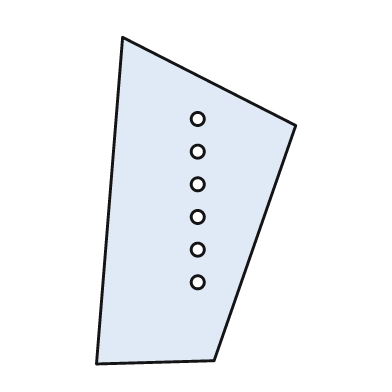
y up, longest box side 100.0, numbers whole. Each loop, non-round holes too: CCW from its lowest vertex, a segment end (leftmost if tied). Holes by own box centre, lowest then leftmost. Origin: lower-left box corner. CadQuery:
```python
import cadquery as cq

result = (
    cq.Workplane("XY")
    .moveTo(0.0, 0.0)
    .lineTo(36.0, 1.0)
    .lineTo(61.0, 73.0)
    .lineTo(8.0, 100.0)
    .close()
    .moveTo(31.0, 25.0)
    .circle(2.0)
    .moveTo(31.0, 35.0)
    .circle(2.0)
    .moveTo(31.0, 45.0)
    .circle(2.0)
    .moveTo(31.0, 55.0)
    .circle(2.0)
    .moveTo(31.0, 65.0)
    .circle(2.0)
    .moveTo(31.0, 75.0)
    .circle(2.0)
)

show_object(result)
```